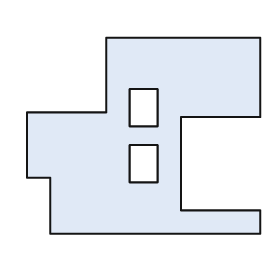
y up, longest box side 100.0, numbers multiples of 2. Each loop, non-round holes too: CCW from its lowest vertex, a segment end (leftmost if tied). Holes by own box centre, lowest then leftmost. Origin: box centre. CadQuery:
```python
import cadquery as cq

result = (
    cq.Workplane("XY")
    .moveTo(-40.0, -42.0)
    .lineTo(50.0, -42.0)
    .lineTo(50.0, -32.0)
    .lineTo(16.0, -32.0)
    .lineTo(16.0, 8.0)
    .lineTo(50.0, 8.0)
    .lineTo(50.0, 42.0)
    .lineTo(-16.0, 42.0)
    .lineTo(-16.0, 10.0)
    .lineTo(-50.0, 10.0)
    .lineTo(-50.0, -18.0)
    .lineTo(-40.0, -18.0)
    .close()
    .moveTo(-6.0, -20.0)
    .lineTo(6.0, -20.0)
    .lineTo(6.0, -4.0)
    .lineTo(-6.0, -4.0)
    .close()
    .moveTo(-6.0, 4.0)
    .lineTo(6.0, 4.0)
    .lineTo(6.0, 20.0)
    .lineTo(-6.0, 20.0)
    .close()
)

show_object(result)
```